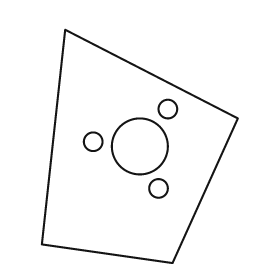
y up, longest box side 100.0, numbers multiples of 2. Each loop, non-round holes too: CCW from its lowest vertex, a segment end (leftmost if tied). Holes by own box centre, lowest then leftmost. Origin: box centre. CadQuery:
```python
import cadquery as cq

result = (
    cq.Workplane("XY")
    .moveTo(14.0, -50.0)
    .lineTo(42.0, 12.0)
    .lineTo(-32.0, 50.0)
    .lineTo(-42.0, -42.0)
    .close()
    .moveTo(8.0, -18.0)
    .circle(4.0)
    .moveTo(0.0, 0.0)
    .circle(12.0)
    .moveTo(-20.0, 2.0)
    .circle(4.0)
    .moveTo(12.0, 16.0)
    .circle(4.0)
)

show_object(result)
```